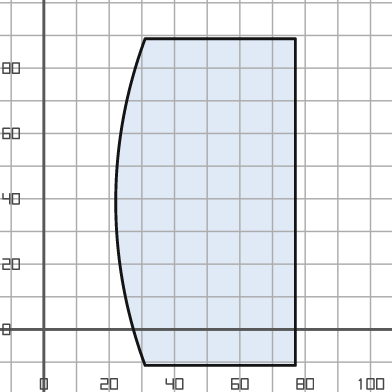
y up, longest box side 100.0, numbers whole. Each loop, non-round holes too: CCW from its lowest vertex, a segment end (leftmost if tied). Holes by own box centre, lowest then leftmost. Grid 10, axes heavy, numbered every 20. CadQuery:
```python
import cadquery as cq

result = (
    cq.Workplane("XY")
    .moveTo(31.0, -11.0)
    .lineTo(77.0, -11.0)
    .lineTo(77.0, 89.0)
    .lineTo(31.0, 89.0)
    .threePointArc((22.0, 39.0), (31.0, -11.0))
    .close()
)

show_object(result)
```